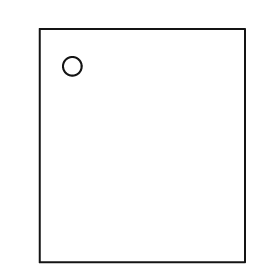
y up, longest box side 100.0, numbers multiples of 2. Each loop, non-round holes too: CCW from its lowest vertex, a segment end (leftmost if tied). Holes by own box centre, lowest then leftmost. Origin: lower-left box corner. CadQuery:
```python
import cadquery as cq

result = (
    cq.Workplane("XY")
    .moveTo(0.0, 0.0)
    .lineTo(88.0, 0.0)
    .lineTo(88.0, 100.0)
    .lineTo(0.0, 100.0)
    .close()
    .moveTo(14.0, 84.0)
    .circle(4.0)
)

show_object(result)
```